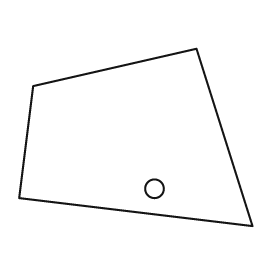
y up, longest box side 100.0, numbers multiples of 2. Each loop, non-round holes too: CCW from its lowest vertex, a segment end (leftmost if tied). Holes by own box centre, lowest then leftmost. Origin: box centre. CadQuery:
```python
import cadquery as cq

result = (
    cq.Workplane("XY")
    .moveTo(50.0, -38.0)
    .lineTo(26.0, 38.0)
    .lineTo(-44.0, 22.0)
    .lineTo(-50.0, -26.0)
    .close()
    .moveTo(8.0, -22.0)
    .circle(4.0)
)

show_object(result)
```